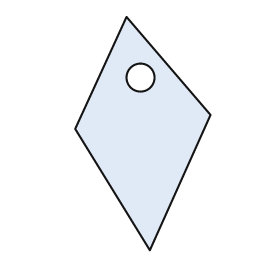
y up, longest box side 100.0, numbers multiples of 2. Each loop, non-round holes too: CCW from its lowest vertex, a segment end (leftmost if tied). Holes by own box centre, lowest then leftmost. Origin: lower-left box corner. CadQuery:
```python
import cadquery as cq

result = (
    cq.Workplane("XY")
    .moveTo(32.0, 0.0)
    .lineTo(58.0, 58.0)
    .lineTo(22.0, 100.0)
    .lineTo(0.0, 52.0)
    .close()
    .moveTo(28.0, 74.0)
    .circle(6.0)
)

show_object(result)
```